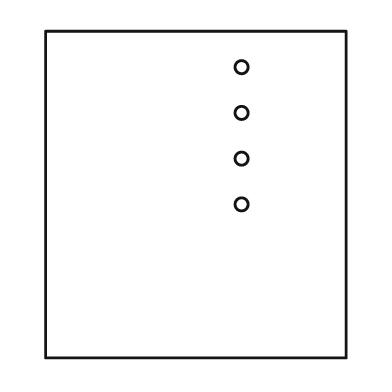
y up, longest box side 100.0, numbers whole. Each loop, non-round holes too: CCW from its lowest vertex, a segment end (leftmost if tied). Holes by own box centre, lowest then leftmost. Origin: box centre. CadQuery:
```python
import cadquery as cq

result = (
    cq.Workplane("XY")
    .moveTo(-46.0, -50.0)
    .lineTo(46.0, -50.0)
    .lineTo(46.0, 50.0)
    .lineTo(-46.0, 50.0)
    .close()
    .moveTo(14.0, -3.0)
    .circle(2.0)
    .moveTo(14.0, 11.0)
    .circle(2.0)
    .moveTo(14.0, 25.0)
    .circle(2.0)
    .moveTo(14.0, 39.0)
    .circle(2.0)
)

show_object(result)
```